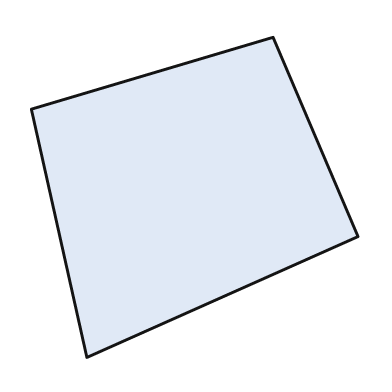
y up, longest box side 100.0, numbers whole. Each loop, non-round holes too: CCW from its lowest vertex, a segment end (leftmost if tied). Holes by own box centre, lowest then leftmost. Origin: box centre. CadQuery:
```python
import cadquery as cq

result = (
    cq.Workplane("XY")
    .moveTo(-33.0, -49.0)
    .lineTo(50.0, -12.0)
    .lineTo(24.0, 49.0)
    .lineTo(-50.0, 27.0)
    .close()
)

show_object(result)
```